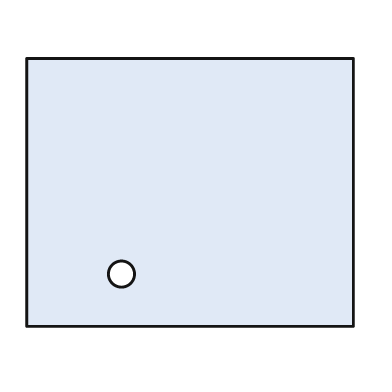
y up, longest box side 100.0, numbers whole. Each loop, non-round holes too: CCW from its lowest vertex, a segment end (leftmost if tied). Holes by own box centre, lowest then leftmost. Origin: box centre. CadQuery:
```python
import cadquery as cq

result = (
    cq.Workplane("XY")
    .moveTo(-50.0, -41.0)
    .lineTo(50.0, -41.0)
    .lineTo(50.0, 41.0)
    .lineTo(-50.0, 41.0)
    .close()
    .moveTo(-21.0, -25.0)
    .circle(4.0)
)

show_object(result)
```